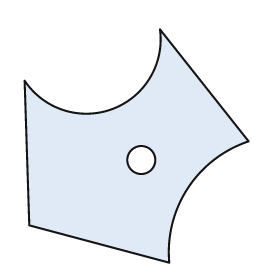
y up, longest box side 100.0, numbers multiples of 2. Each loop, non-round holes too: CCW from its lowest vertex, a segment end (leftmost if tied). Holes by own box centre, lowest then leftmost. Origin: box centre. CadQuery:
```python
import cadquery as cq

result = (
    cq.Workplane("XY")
    .moveTo(14.0, -50.0)
    .threePointArc((22.0, -18.0), (48.0, 2.0))
    .lineTo(10.0, 50.0)
    .threePointArc((-10.0, 16.0), (-48.0, 28.0))
    .lineTo(-46.0, -34.0)
    .close()
    .moveTo(2.0, -6.0)
    .circle(6.0)
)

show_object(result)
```